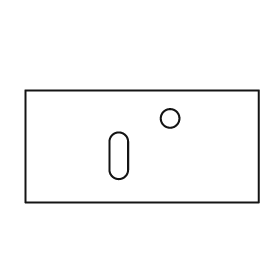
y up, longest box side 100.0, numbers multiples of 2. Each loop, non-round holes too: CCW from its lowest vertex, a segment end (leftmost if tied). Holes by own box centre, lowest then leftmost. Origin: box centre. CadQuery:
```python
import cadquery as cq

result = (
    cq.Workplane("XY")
    .moveTo(-50.0, -24.0)
    .lineTo(50.0, -24.0)
    .lineTo(50.0, 24.0)
    .lineTo(-50.0, 24.0)
    .close()
    .moveTo(-14.0, -10.0)
    .threePointArc((-10.0, -14.0), (-6.0, -10.0))
    .lineTo(-6.0, 2.0)
    .threePointArc((-10.0, 6.0), (-14.0, 2.0))
    .close()
    .moveTo(12.0, 12.0)
    .circle(4.0)
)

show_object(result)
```